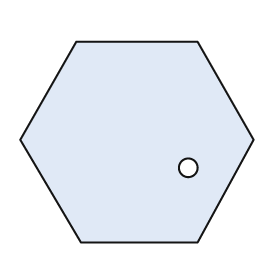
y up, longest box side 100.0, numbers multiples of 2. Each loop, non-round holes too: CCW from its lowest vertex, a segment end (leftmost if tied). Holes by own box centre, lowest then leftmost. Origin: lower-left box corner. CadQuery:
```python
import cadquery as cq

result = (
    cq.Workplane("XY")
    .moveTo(26.0, 0.0)
    .lineTo(76.0, 0.0)
    .lineTo(100.0, 44.0)
    .lineTo(76.0, 86.0)
    .lineTo(24.0, 86.0)
    .lineTo(0.0, 44.0)
    .close()
    .moveTo(72.0, 32.0)
    .circle(4.0)
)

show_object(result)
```